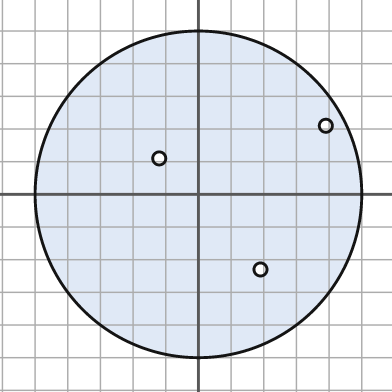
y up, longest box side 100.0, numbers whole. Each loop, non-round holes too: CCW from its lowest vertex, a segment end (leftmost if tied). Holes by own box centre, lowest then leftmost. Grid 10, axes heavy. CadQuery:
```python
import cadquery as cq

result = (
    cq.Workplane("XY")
    .moveTo(0.0, 0.0)
    .circle(50.0)
    .moveTo(19.0, -23.0)
    .circle(2.0)
    .moveTo(-12.0, 11.0)
    .circle(2.0)
    .moveTo(39.0, 21.0)
    .circle(2.0)
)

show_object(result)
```